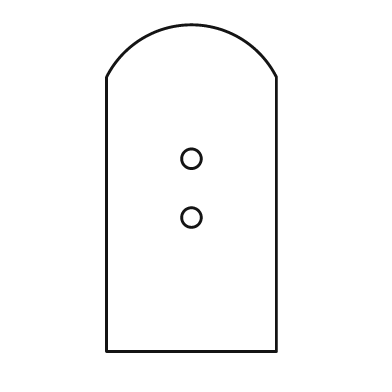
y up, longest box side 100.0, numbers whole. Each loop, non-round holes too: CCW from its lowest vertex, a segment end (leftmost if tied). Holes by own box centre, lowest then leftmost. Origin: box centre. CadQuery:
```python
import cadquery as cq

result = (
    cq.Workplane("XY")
    .moveTo(-26.0, -50.0)
    .lineTo(26.0, -50.0)
    .lineTo(26.0, 34.0)
    .threePointArc((0.0, 50.0), (-26.0, 34.0))
    .close()
    .moveTo(0.0, -9.0)
    .circle(3.0)
    .moveTo(0.0, 9.0)
    .circle(3.0)
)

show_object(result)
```